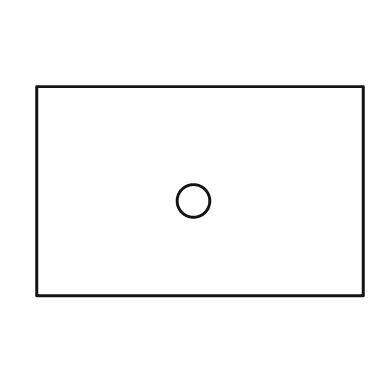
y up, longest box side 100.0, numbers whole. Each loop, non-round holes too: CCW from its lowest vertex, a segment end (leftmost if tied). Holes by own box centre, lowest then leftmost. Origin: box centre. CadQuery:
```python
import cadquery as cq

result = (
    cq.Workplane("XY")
    .moveTo(-50.0, -32.0)
    .lineTo(50.0, -32.0)
    .lineTo(50.0, 32.0)
    .lineTo(-50.0, 32.0)
    .close()
    .moveTo(-2.0, -3.0)
    .circle(5.0)
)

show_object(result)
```